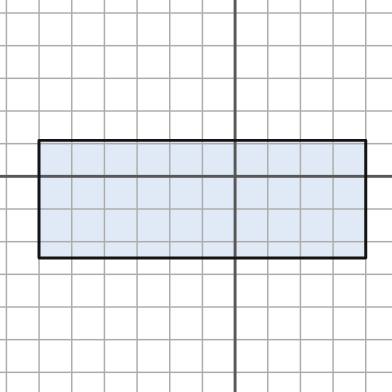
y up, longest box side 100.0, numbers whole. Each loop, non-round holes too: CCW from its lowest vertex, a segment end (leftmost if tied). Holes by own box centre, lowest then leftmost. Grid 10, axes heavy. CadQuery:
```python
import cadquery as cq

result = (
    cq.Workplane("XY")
    .moveTo(-60.0, -25.0)
    .lineTo(40.0, -25.0)
    .lineTo(40.0, 11.0)
    .lineTo(-60.0, 11.0)
    .close()
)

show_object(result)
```